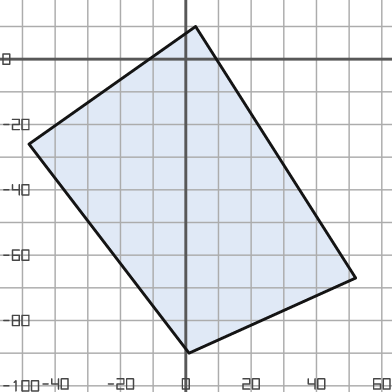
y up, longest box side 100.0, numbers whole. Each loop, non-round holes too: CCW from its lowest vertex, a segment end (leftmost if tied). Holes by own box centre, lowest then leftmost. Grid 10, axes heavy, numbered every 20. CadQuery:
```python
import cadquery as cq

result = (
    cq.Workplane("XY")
    .moveTo(1.0, -90.0)
    .lineTo(52.0, -67.0)
    .lineTo(3.0, 10.0)
    .lineTo(-48.0, -26.0)
    .close()
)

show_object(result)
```